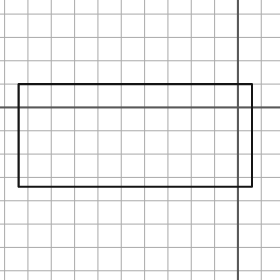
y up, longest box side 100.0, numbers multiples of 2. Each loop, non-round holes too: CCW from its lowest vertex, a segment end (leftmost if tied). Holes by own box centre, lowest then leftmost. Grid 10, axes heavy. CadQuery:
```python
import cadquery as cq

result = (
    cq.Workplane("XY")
    .moveTo(-94.0, -34.0)
    .lineTo(6.0, -34.0)
    .lineTo(6.0, 10.0)
    .lineTo(-94.0, 10.0)
    .close()
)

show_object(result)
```